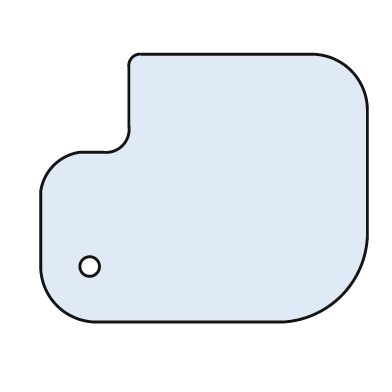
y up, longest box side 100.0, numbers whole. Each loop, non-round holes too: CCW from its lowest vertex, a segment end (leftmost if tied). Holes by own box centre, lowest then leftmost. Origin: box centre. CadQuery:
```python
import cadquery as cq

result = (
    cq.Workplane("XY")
    .moveTo(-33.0, -41.0)
    .lineTo(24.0, -41.0)
    .threePointArc((42.0, -33.0), (50.0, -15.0))
    .lineTo(50.0, 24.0)
    .threePointArc((45.0, 36.0), (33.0, 41.0))
    .lineTo(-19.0, 41.0)
    .threePointArc((-22.0, 40.0), (-23.0, 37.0))
    .lineTo(-23.0, 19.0)
    .threePointArc((-25.0, 13.0), (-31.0, 11.0))
    .lineTo(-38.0, 11.0)
    .threePointArc((-46.0, 7.0), (-50.0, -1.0))
    .lineTo(-50.0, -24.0)
    .threePointArc((-45.0, -36.0), (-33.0, -41.0))
    .close()
    .moveTo(-35.0, -24.0)
    .circle(3.0)
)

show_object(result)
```